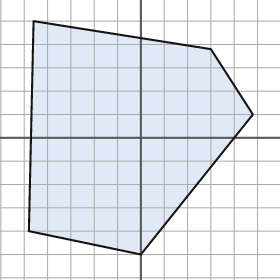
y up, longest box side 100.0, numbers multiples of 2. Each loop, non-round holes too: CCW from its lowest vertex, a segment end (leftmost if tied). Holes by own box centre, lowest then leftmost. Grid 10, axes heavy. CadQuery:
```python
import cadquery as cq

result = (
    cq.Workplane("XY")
    .moveTo(0.0, -50.0)
    .lineTo(48.0, 10.0)
    .lineTo(30.0, 38.0)
    .lineTo(-46.0, 50.0)
    .lineTo(-48.0, -40.0)
    .close()
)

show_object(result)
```